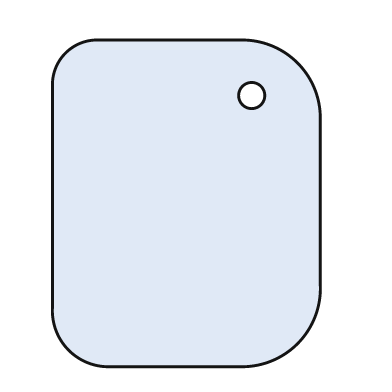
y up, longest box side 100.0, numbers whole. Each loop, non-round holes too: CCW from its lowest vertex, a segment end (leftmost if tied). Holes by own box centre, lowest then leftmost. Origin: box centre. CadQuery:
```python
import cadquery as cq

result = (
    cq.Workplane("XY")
    .moveTo(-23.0, -50.0)
    .lineTo(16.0, -50.0)
    .threePointArc((34.0, -43.0), (41.0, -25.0))
    .lineTo(41.0, 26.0)
    .threePointArc((34.0, 43.0), (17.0, 50.0))
    .lineTo(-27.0, 50.0)
    .threePointArc((-37.0, 46.0), (-41.0, 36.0))
    .lineTo(-41.0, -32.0)
    .threePointArc((-36.0, -45.0), (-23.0, -50.0))
    .close()
    .moveTo(20.0, 33.0)
    .circle(4.0)
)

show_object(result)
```